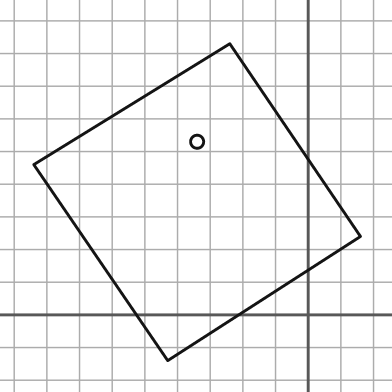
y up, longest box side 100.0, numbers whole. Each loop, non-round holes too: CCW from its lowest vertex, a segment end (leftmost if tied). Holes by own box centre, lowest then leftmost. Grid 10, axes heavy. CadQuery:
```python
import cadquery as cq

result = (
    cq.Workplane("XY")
    .moveTo(-43.0, -14.0)
    .lineTo(16.0, 24.0)
    .lineTo(-24.0, 83.0)
    .lineTo(-84.0, 46.0)
    .close()
    .moveTo(-34.0, 53.0)
    .circle(2.0)
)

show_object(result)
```